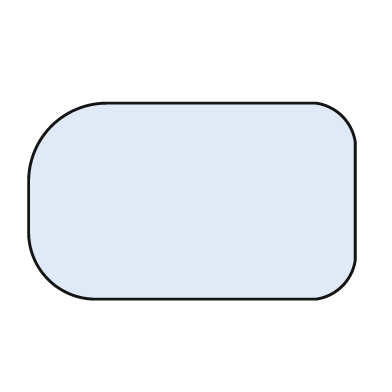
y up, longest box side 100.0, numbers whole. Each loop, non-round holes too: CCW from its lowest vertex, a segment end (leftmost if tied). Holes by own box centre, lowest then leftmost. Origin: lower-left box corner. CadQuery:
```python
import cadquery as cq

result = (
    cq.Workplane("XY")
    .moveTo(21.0, 0.0)
    .lineTo(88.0, 0.0)
    .threePointArc((96.0, 4.0), (100.0, 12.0))
    .lineTo(100.0, 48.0)
    .threePointArc((96.0, 56.0), (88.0, 60.0))
    .lineTo(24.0, 60.0)
    .threePointArc((7.0, 53.0), (0.0, 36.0))
    .lineTo(0.0, 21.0)
    .threePointArc((6.0, 6.0), (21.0, 0.0))
    .close()
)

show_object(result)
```